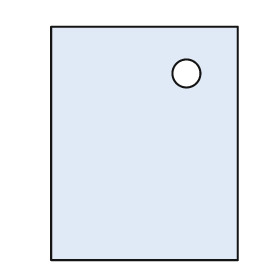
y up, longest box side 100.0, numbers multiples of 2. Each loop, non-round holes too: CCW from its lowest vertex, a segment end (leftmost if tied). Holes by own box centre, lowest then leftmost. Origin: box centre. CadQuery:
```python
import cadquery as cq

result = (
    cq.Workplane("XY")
    .moveTo(-40.0, -50.0)
    .lineTo(40.0, -50.0)
    .lineTo(40.0, 50.0)
    .lineTo(-40.0, 50.0)
    .close()
    .moveTo(18.0, 30.0)
    .circle(6.0)
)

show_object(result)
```